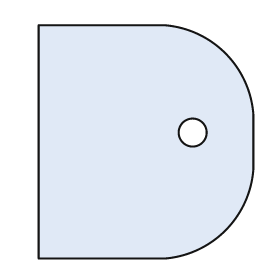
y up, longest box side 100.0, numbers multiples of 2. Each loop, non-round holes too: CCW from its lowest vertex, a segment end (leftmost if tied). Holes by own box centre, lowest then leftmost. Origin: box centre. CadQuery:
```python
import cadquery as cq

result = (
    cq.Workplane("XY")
    .moveTo(-46.0, -50.0)
    .lineTo(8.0, -50.0)
    .threePointArc((34.0, -38.0), (46.0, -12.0))
    .lineTo(46.0, 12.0)
    .threePointArc((34.0, 38.0), (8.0, 50.0))
    .lineTo(-46.0, 50.0)
    .close()
    .moveTo(20.0, 4.0)
    .circle(6.0)
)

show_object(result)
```